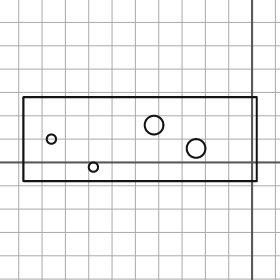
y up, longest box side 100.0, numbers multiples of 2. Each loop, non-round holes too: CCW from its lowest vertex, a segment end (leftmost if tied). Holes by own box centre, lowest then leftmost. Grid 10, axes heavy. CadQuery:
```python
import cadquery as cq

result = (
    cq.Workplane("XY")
    .moveTo(-98.0, -8.0)
    .lineTo(2.0, -8.0)
    .lineTo(2.0, 28.0)
    .lineTo(-98.0, 28.0)
    .close()
    .moveTo(-68.0, -2.0)
    .circle(2.0)
    .moveTo(-24.0, 6.0)
    .circle(4.0)
    .moveTo(-86.0, 10.0)
    .circle(2.0)
    .moveTo(-42.0, 16.0)
    .circle(4.0)
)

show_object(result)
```